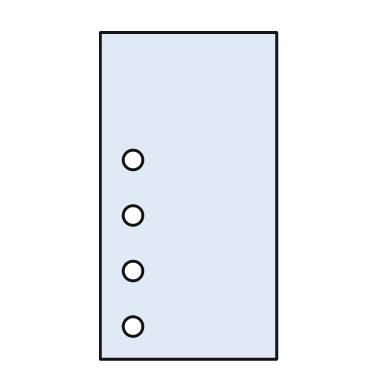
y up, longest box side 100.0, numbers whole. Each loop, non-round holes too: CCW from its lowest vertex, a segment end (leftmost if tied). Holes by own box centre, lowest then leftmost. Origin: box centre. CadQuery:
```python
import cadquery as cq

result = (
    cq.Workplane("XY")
    .moveTo(-27.0, -50.0)
    .lineTo(27.0, -50.0)
    .lineTo(27.0, 50.0)
    .lineTo(-27.0, 50.0)
    .close()
    .moveTo(-17.0, -40.0)
    .circle(3.0)
    .moveTo(-17.0, -23.0)
    .circle(3.0)
    .moveTo(-17.0, -6.0)
    .circle(3.0)
    .moveTo(-17.0, 11.0)
    .circle(3.0)
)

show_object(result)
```